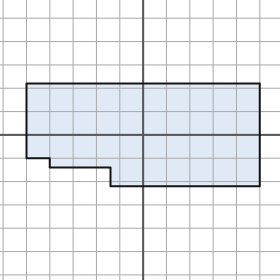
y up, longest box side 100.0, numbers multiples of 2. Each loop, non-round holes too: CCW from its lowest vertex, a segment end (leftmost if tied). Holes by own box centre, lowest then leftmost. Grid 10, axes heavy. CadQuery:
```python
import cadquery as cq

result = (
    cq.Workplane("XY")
    .moveTo(-14.0, -22.0)
    .lineTo(50.0, -22.0)
    .lineTo(50.0, 22.0)
    .lineTo(-50.0, 22.0)
    .lineTo(-50.0, -10.0)
    .lineTo(-40.0, -10.0)
    .lineTo(-40.0, -14.0)
    .lineTo(-14.0, -14.0)
    .close()
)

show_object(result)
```